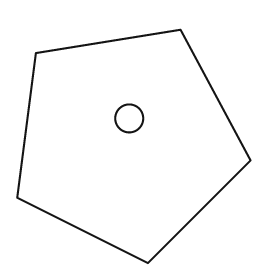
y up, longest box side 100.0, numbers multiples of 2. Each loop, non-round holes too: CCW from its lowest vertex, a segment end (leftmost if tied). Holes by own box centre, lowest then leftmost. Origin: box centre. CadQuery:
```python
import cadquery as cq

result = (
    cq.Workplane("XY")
    .moveTo(6.0, -50.0)
    .lineTo(50.0, -6.0)
    .lineTo(20.0, 50.0)
    .lineTo(-42.0, 40.0)
    .lineTo(-50.0, -22.0)
    .close()
    .moveTo(-2.0, 12.0)
    .circle(6.0)
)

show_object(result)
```